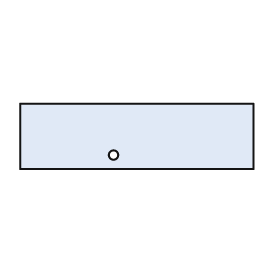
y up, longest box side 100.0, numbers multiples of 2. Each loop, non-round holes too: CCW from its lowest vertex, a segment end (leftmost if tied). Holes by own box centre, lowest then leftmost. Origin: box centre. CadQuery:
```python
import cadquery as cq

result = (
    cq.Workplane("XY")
    .moveTo(-50.0, -14.0)
    .lineTo(50.0, -14.0)
    .lineTo(50.0, 14.0)
    .lineTo(-50.0, 14.0)
    .close()
    .moveTo(-10.0, -8.0)
    .circle(2.0)
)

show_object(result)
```